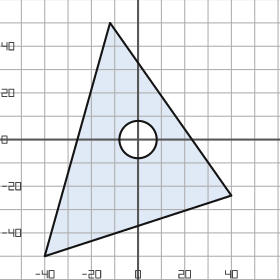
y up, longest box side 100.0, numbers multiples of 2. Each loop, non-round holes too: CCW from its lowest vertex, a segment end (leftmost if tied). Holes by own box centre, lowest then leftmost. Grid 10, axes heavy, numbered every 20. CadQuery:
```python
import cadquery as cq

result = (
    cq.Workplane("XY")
    .moveTo(-40.0, -50.0)
    .lineTo(40.0, -24.0)
    .lineTo(-12.0, 50.0)
    .close()
    .moveTo(0.0, 0.0)
    .circle(8.0)
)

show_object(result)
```